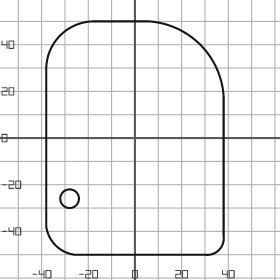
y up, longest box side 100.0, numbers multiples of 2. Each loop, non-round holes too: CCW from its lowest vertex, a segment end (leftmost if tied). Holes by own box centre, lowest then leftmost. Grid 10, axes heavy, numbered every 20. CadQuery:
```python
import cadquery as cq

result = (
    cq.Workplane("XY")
    .moveTo(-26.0, -50.0)
    .lineTo(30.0, -50.0)
    .threePointArc((36.0, -48.0), (38.0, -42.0))
    .lineTo(38.0, 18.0)
    .threePointArc((28.0, 40.0), (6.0, 50.0))
    .lineTo(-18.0, 50.0)
    .threePointArc((-32.0, 44.0), (-38.0, 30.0))
    .lineTo(-38.0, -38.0)
    .threePointArc((-34.0, -46.0), (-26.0, -50.0))
    .close()
    .moveTo(-28.0, -26.0)
    .circle(4.0)
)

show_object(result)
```